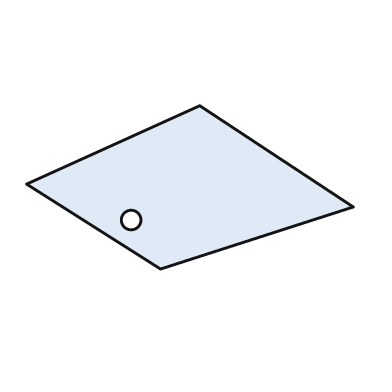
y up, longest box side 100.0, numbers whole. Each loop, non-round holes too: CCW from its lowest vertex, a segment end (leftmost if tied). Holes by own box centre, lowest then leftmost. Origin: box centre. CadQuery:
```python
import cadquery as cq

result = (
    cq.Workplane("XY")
    .moveTo(-9.0, -25.0)
    .lineTo(50.0, -6.0)
    .lineTo(3.0, 25.0)
    .lineTo(-50.0, 1.0)
    .close()
    .moveTo(-18.0, -10.0)
    .circle(3.0)
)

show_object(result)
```